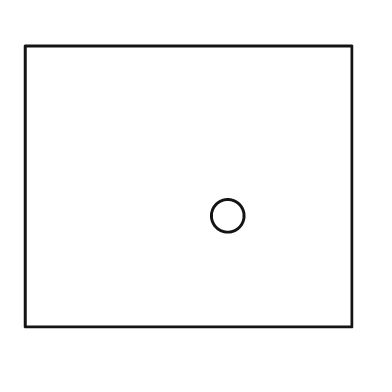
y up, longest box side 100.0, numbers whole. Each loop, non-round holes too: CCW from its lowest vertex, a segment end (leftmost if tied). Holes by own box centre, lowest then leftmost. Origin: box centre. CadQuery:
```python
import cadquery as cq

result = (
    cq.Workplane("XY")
    .moveTo(-50.0, -43.0)
    .lineTo(50.0, -43.0)
    .lineTo(50.0, 43.0)
    .lineTo(-50.0, 43.0)
    .close()
    .moveTo(12.0, -9.0)
    .circle(5.0)
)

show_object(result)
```